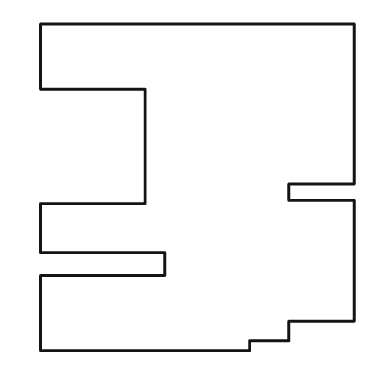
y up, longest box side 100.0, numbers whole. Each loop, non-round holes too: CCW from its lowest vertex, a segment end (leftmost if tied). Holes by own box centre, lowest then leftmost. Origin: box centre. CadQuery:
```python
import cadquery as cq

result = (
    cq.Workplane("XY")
    .moveTo(-48.0, -50.0)
    .lineTo(16.0, -50.0)
    .lineTo(16.0, -47.0)
    .lineTo(28.0, -47.0)
    .lineTo(28.0, -41.0)
    .lineTo(48.0, -41.0)
    .lineTo(48.0, -4.0)
    .lineTo(28.0, -4.0)
    .lineTo(28.0, 1.0)
    .lineTo(48.0, 1.0)
    .lineTo(48.0, 50.0)
    .lineTo(-48.0, 50.0)
    .lineTo(-48.0, 30.0)
    .lineTo(-16.0, 30.0)
    .lineTo(-16.0, -5.0)
    .lineTo(-48.0, -5.0)
    .lineTo(-48.0, -20.0)
    .lineTo(-10.0, -20.0)
    .lineTo(-10.0, -27.0)
    .lineTo(-48.0, -27.0)
    .close()
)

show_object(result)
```